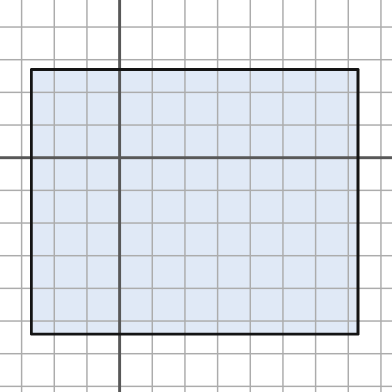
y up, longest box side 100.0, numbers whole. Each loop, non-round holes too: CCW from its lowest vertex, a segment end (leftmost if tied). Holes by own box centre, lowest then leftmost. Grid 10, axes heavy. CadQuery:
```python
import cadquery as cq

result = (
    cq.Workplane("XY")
    .moveTo(-27.0, -54.0)
    .lineTo(73.0, -54.0)
    .lineTo(73.0, 27.0)
    .lineTo(-27.0, 27.0)
    .close()
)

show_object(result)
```